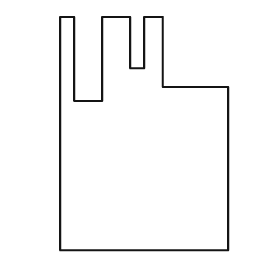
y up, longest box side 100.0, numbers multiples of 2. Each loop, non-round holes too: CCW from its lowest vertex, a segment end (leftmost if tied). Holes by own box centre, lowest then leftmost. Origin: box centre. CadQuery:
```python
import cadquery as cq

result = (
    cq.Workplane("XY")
    .moveTo(-36.0, -50.0)
    .lineTo(36.0, -50.0)
    .lineTo(36.0, 20.0)
    .lineTo(8.0, 20.0)
    .lineTo(8.0, 50.0)
    .lineTo(0.0, 50.0)
    .lineTo(0.0, 28.0)
    .lineTo(-6.0, 28.0)
    .lineTo(-6.0, 50.0)
    .lineTo(-18.0, 50.0)
    .lineTo(-18.0, 14.0)
    .lineTo(-30.0, 14.0)
    .lineTo(-30.0, 50.0)
    .lineTo(-36.0, 50.0)
    .close()
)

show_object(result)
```